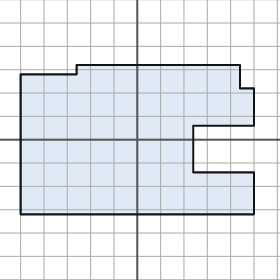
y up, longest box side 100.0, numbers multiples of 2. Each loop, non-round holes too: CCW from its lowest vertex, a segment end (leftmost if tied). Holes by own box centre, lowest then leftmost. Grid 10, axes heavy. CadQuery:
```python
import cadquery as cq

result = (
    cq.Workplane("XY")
    .moveTo(-50.0, -32.0)
    .lineTo(50.0, -32.0)
    .lineTo(50.0, -14.0)
    .lineTo(24.0, -14.0)
    .lineTo(24.0, 6.0)
    .lineTo(50.0, 6.0)
    .lineTo(50.0, 22.0)
    .lineTo(44.0, 22.0)
    .lineTo(44.0, 32.0)
    .lineTo(-26.0, 32.0)
    .lineTo(-26.0, 28.0)
    .lineTo(-50.0, 28.0)
    .close()
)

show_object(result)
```